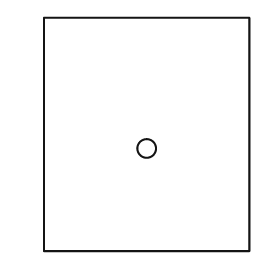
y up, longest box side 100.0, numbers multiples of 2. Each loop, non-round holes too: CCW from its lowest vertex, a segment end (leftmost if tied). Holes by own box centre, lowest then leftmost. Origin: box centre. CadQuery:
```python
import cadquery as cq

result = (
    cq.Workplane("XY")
    .moveTo(-44.0, -50.0)
    .lineTo(44.0, -50.0)
    .lineTo(44.0, 50.0)
    .lineTo(-44.0, 50.0)
    .close()
    .moveTo(0.0, -6.0)
    .circle(4.0)
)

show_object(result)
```